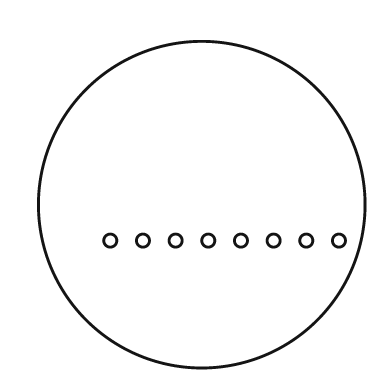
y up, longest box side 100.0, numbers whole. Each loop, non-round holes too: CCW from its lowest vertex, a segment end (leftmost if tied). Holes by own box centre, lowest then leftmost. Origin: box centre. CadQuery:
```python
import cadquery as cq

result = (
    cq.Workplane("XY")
    .moveTo(0.0, 0.0)
    .circle(50.0)
    .moveTo(-28.0, -11.0)
    .circle(2.0)
    .moveTo(-18.0, -11.0)
    .circle(2.0)
    .moveTo(-8.0, -11.0)
    .circle(2.0)
    .moveTo(2.0, -11.0)
    .circle(2.0)
    .moveTo(12.0, -11.0)
    .circle(2.0)
    .moveTo(22.0, -11.0)
    .circle(2.0)
    .moveTo(32.0, -11.0)
    .circle(2.0)
    .moveTo(42.0, -11.0)
    .circle(2.0)
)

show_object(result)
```